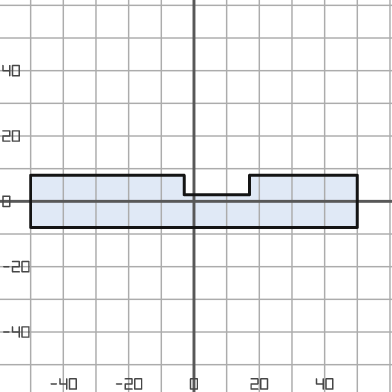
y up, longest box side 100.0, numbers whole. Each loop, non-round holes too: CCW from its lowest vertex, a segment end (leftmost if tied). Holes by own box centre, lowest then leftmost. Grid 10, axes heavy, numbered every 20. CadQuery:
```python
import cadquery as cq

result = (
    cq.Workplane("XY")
    .moveTo(-50.0, -8.0)
    .lineTo(50.0, -8.0)
    .lineTo(50.0, 8.0)
    .lineTo(17.0, 8.0)
    .lineTo(17.0, 2.0)
    .lineTo(-3.0, 2.0)
    .lineTo(-3.0, 8.0)
    .lineTo(-50.0, 8.0)
    .close()
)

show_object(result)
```